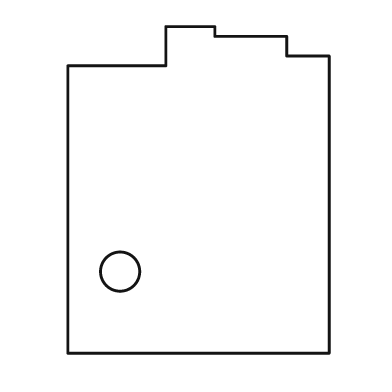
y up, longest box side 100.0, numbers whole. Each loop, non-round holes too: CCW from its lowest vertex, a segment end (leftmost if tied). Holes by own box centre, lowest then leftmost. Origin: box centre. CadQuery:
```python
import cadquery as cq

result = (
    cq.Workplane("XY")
    .moveTo(-40.0, -50.0)
    .lineTo(40.0, -50.0)
    .lineTo(40.0, 41.0)
    .lineTo(27.0, 41.0)
    .lineTo(27.0, 47.0)
    .lineTo(5.0, 47.0)
    .lineTo(5.0, 50.0)
    .lineTo(-10.0, 50.0)
    .lineTo(-10.0, 38.0)
    .lineTo(-40.0, 38.0)
    .close()
    .moveTo(-24.0, -25.0)
    .circle(6.0)
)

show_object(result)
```